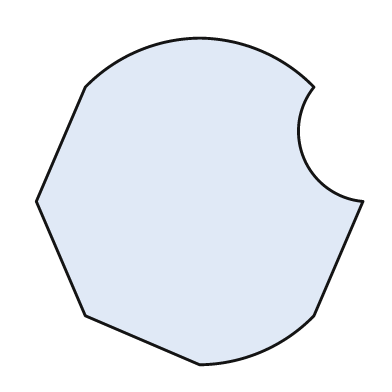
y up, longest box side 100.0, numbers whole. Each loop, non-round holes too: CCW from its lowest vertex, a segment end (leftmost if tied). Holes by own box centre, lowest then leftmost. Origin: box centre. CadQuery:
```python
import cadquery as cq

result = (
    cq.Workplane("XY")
    .moveTo(0.0, -50.0)
    .threePointArc((19.0, -46.0), (35.0, -35.0))
    .lineTo(50.0, 0.0)
    .threePointArc((32.0, 13.0), (35.0, 35.0))
    .threePointArc((19.0, 46.0), (0.0, 50.0))
    .threePointArc((-19.0, 46.0), (-35.0, 35.0))
    .lineTo(-50.0, 0.0)
    .lineTo(-35.0, -35.0)
    .close()
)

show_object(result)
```